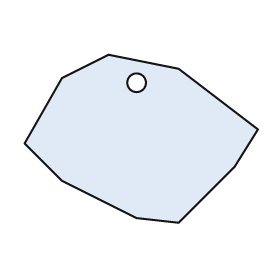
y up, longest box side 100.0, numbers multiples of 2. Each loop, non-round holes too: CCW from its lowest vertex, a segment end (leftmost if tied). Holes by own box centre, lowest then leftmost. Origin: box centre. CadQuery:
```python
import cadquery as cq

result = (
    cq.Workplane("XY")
    .moveTo(16.0, -36.0)
    .lineTo(40.0, -12.0)
    .lineTo(50.0, 4.0)
    .lineTo(16.0, 30.0)
    .lineTo(-14.0, 36.0)
    .lineTo(-34.0, 26.0)
    .lineTo(-50.0, -2.0)
    .lineTo(-34.0, -18.0)
    .lineTo(-2.0, -34.0)
    .close()
    .moveTo(-2.0, 24.0)
    .circle(4.0)
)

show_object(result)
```